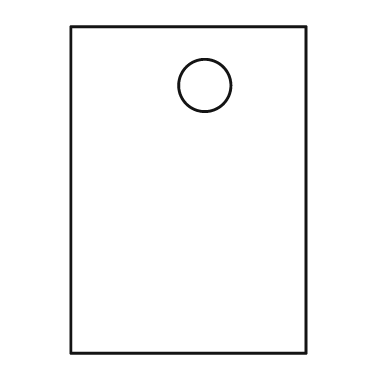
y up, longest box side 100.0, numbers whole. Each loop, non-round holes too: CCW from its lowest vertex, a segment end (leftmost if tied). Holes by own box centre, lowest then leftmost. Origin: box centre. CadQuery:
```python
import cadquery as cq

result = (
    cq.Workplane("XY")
    .moveTo(-36.0, -50.0)
    .lineTo(36.0, -50.0)
    .lineTo(36.0, 50.0)
    .lineTo(-36.0, 50.0)
    .close()
    .moveTo(5.0, 32.0)
    .circle(8.0)
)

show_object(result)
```